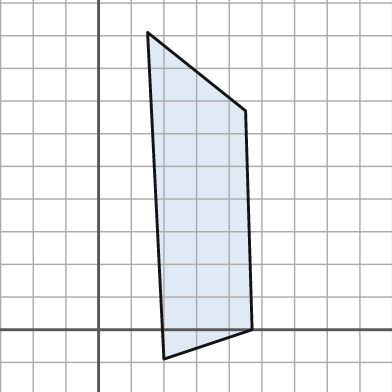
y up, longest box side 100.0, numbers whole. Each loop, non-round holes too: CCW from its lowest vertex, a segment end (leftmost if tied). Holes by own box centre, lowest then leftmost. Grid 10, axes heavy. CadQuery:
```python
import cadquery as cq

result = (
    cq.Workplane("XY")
    .moveTo(20.0, -9.0)
    .lineTo(47.0, 0.0)
    .lineTo(45.0, 67.0)
    .lineTo(15.0, 91.0)
    .close()
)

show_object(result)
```